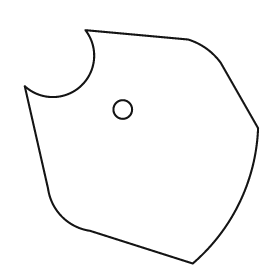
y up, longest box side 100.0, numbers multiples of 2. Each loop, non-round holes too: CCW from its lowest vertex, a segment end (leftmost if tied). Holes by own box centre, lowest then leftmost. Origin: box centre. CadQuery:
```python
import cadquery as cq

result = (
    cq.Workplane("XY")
    .moveTo(22.0, -50.0)
    .threePointArc((42.0, -24.0), (50.0, 8.0))
    .lineTo(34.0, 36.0)
    .threePointArc((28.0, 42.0), (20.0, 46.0))
    .lineTo(-24.0, 50.0)
    .threePointArc((-26.0, 26.0), (-50.0, 26.0))
    .lineTo(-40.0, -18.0)
    .threePointArc((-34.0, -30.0), (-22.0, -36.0))
    .close()
    .moveTo(-8.0, 16.0)
    .circle(4.0)
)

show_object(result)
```